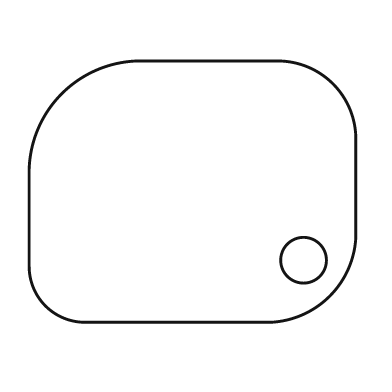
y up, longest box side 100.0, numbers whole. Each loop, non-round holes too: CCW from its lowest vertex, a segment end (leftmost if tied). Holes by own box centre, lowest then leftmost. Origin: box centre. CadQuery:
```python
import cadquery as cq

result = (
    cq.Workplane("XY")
    .moveTo(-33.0, -40.0)
    .lineTo(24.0, -40.0)
    .threePointArc((42.0, -32.0), (50.0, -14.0))
    .lineTo(50.0, 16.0)
    .threePointArc((43.0, 33.0), (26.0, 40.0))
    .lineTo(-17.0, 40.0)
    .threePointArc((-40.0, 30.0), (-50.0, 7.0))
    .lineTo(-50.0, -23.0)
    .threePointArc((-45.0, -35.0), (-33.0, -40.0))
    .close()
    .moveTo(34.0, -21.0)
    .circle(7.0)
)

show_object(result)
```